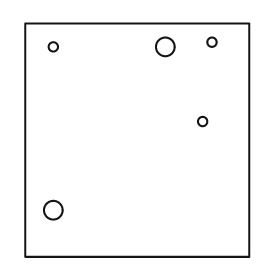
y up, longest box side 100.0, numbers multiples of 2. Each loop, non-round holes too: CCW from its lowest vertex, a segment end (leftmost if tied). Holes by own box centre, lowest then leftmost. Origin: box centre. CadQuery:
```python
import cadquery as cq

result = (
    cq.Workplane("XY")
    .moveTo(-48.0, -50.0)
    .lineTo(48.0, -50.0)
    .lineTo(48.0, 50.0)
    .lineTo(-48.0, 50.0)
    .close()
    .moveTo(-36.0, -30.0)
    .circle(4.0)
    .moveTo(28.0, 8.0)
    .circle(2.0)
    .moveTo(-36.0, 40.0)
    .circle(2.0)
    .moveTo(12.0, 40.0)
    .circle(4.0)
    .moveTo(32.0, 42.0)
    .circle(2.0)
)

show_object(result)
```